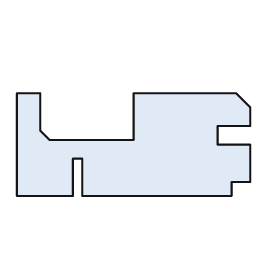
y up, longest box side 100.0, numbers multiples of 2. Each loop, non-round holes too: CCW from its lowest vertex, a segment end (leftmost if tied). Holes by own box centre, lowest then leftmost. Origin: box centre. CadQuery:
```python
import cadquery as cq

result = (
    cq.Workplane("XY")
    .moveTo(-50.0, -22.0)
    .lineTo(-26.0, -22.0)
    .lineTo(-26.0, -6.0)
    .lineTo(-22.0, -6.0)
    .lineTo(-22.0, -22.0)
    .lineTo(42.0, -22.0)
    .lineTo(42.0, -16.0)
    .lineTo(50.0, -16.0)
    .lineTo(50.0, 0.0)
    .lineTo(36.0, 0.0)
    .lineTo(36.0, 8.0)
    .lineTo(50.0, 8.0)
    .lineTo(50.0, 16.0)
    .lineTo(44.0, 22.0)
    .lineTo(0.0, 22.0)
    .lineTo(0.0, 2.0)
    .lineTo(-36.0, 2.0)
    .lineTo(-40.0, 6.0)
    .lineTo(-40.0, 22.0)
    .lineTo(-50.0, 22.0)
    .close()
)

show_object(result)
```